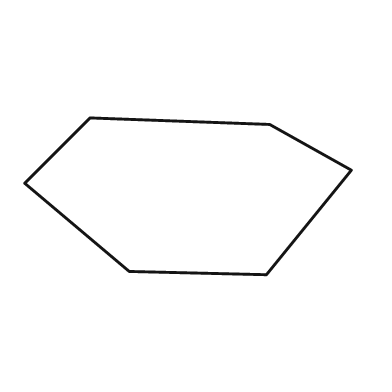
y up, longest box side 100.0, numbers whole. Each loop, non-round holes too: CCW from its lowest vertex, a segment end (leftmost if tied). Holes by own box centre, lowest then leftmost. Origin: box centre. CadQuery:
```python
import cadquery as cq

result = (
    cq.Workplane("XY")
    .moveTo(24.0, -24.0)
    .lineTo(50.0, 8.0)
    .lineTo(25.0, 22.0)
    .lineTo(-30.0, 24.0)
    .lineTo(-50.0, 4.0)
    .lineTo(-18.0, -23.0)
    .close()
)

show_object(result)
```